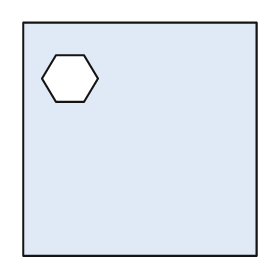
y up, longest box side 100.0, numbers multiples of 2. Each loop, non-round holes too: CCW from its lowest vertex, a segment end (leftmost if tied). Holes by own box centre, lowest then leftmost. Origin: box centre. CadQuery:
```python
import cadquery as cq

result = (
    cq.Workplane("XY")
    .moveTo(-50.0, -50.0)
    .lineTo(50.0, -50.0)
    .lineTo(50.0, 50.0)
    .lineTo(-50.0, 50.0)
    .close()
    .moveTo(-36.0, 16.0)
    .lineTo(-24.0, 16.0)
    .lineTo(-18.0, 26.0)
    .lineTo(-24.0, 36.0)
    .lineTo(-36.0, 36.0)
    .lineTo(-42.0, 26.0)
    .close()
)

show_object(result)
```